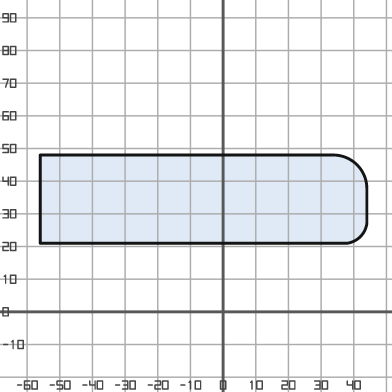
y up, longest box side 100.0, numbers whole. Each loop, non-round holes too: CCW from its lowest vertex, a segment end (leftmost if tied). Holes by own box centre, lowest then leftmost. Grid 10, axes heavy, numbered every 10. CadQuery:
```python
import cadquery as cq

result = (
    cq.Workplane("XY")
    .moveTo(-56.0, 21.0)
    .lineTo(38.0, 21.0)
    .threePointArc((42.0, 23.0), (44.0, 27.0))
    .lineTo(44.0, 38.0)
    .threePointArc((41.0, 45.0), (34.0, 48.0))
    .lineTo(-56.0, 48.0)
    .close()
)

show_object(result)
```